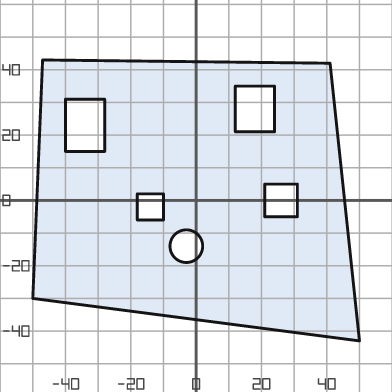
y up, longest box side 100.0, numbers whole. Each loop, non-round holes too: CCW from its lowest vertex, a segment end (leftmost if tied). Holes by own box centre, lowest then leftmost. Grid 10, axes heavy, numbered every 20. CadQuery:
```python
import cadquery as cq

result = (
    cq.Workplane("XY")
    .moveTo(50.0, -43.0)
    .lineTo(41.0, 42.0)
    .lineTo(-47.0, 43.0)
    .lineTo(-50.0, -30.0)
    .close()
    .moveTo(-3.0, -14.0)
    .circle(5.0)
    .moveTo(-18.0, -6.0)
    .lineTo(-10.0, -6.0)
    .lineTo(-10.0, 2.0)
    .lineTo(-18.0, 2.0)
    .close()
    .moveTo(21.0, -5.0)
    .lineTo(31.0, -5.0)
    .lineTo(31.0, 5.0)
    .lineTo(21.0, 5.0)
    .close()
    .moveTo(-40.0, 15.0)
    .lineTo(-28.0, 15.0)
    .lineTo(-28.0, 31.0)
    .lineTo(-40.0, 31.0)
    .close()
    .moveTo(12.0, 21.0)
    .lineTo(24.0, 21.0)
    .lineTo(24.0, 35.0)
    .lineTo(12.0, 35.0)
    .close()
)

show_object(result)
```